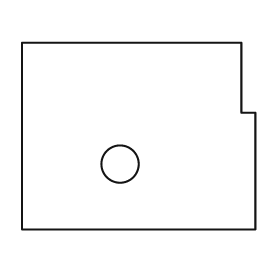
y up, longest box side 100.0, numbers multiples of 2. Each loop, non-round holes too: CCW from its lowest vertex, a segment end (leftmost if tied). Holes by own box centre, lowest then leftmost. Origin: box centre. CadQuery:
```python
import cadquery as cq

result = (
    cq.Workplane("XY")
    .moveTo(-50.0, -40.0)
    .lineTo(50.0, -40.0)
    .lineTo(50.0, 10.0)
    .lineTo(44.0, 10.0)
    .lineTo(44.0, 40.0)
    .lineTo(-50.0, 40.0)
    .close()
    .moveTo(-8.0, -12.0)
    .circle(8.0)
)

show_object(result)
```